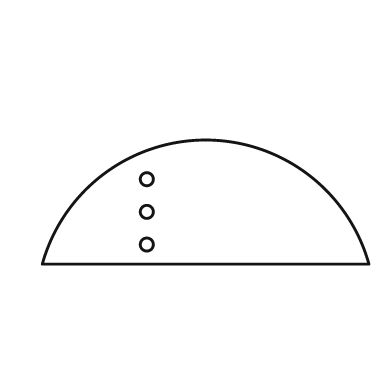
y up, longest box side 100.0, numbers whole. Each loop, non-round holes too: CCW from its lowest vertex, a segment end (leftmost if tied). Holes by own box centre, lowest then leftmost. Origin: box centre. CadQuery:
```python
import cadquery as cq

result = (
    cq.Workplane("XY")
    .moveTo(-50.0, -19.0)
    .lineTo(50.0, -19.0)
    .threePointArc((0.0, 19.0), (-50.0, -19.0))
    .close()
    .moveTo(-18.0, -13.0)
    .circle(2.0)
    .moveTo(-18.0, -3.0)
    .circle(2.0)
    .moveTo(-18.0, 7.0)
    .circle(2.0)
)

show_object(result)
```